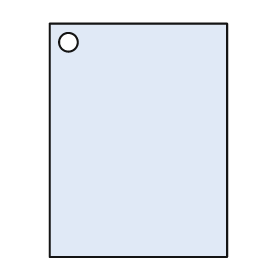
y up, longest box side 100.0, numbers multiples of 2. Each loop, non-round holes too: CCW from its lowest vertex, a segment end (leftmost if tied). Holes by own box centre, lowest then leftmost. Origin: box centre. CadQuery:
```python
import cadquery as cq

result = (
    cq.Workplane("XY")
    .moveTo(-38.0, -50.0)
    .lineTo(38.0, -50.0)
    .lineTo(38.0, 50.0)
    .lineTo(-38.0, 50.0)
    .close()
    .moveTo(-30.0, 42.0)
    .circle(4.0)
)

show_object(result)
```